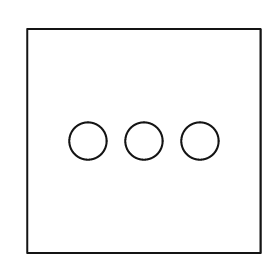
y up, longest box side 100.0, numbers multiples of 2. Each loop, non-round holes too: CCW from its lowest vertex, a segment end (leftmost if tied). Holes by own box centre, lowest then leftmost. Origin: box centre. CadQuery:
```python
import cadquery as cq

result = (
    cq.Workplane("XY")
    .moveTo(-50.0, -48.0)
    .lineTo(50.0, -48.0)
    .lineTo(50.0, 48.0)
    .lineTo(-50.0, 48.0)
    .close()
    .moveTo(-24.0, 0.0)
    .circle(8.0)
    .moveTo(0.0, 0.0)
    .circle(8.0)
    .moveTo(24.0, 0.0)
    .circle(8.0)
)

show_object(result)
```